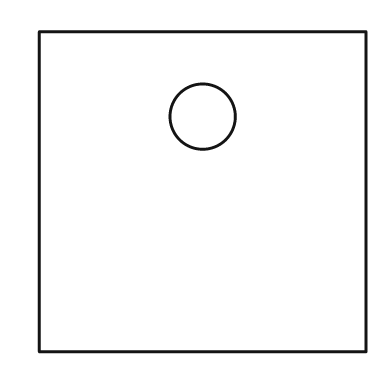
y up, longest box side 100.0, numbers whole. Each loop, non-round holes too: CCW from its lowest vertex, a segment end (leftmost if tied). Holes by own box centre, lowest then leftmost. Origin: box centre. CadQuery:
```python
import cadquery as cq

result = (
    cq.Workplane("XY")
    .moveTo(-50.0, -49.0)
    .lineTo(50.0, -49.0)
    .lineTo(50.0, 49.0)
    .lineTo(-50.0, 49.0)
    .close()
    .moveTo(0.0, 23.0)
    .circle(10.0)
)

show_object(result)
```